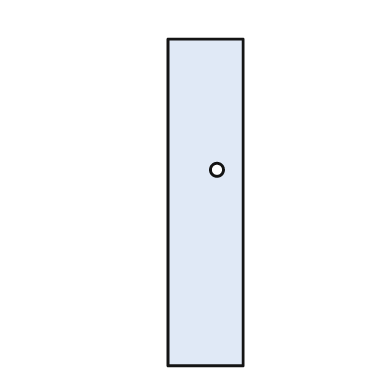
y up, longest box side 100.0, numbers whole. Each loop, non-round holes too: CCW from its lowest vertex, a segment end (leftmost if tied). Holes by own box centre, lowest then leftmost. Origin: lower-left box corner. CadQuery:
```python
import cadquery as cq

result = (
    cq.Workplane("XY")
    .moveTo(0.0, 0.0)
    .lineTo(23.0, 0.0)
    .lineTo(23.0, 100.0)
    .lineTo(0.0, 100.0)
    .close()
    .moveTo(15.0, 60.0)
    .circle(2.0)
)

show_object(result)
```